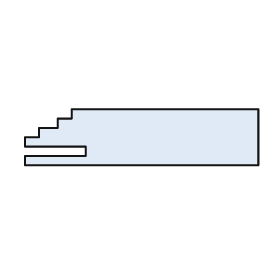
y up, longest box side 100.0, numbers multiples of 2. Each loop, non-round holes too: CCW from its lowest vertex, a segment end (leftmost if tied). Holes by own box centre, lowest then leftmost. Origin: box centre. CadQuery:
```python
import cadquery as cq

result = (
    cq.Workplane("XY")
    .moveTo(-50.0, -12.0)
    .lineTo(50.0, -12.0)
    .lineTo(50.0, 12.0)
    .lineTo(-30.0, 12.0)
    .lineTo(-30.0, 8.0)
    .lineTo(-36.0, 8.0)
    .lineTo(-36.0, 4.0)
    .lineTo(-44.0, 4.0)
    .lineTo(-44.0, 0.0)
    .lineTo(-50.0, 0.0)
    .lineTo(-50.0, -4.0)
    .lineTo(-24.0, -4.0)
    .lineTo(-24.0, -8.0)
    .lineTo(-50.0, -8.0)
    .close()
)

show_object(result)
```